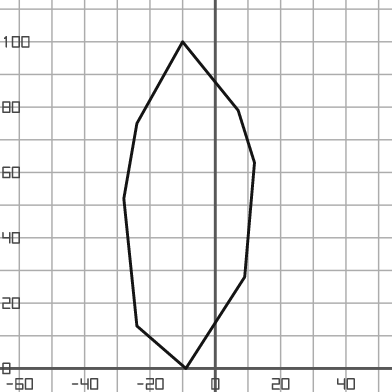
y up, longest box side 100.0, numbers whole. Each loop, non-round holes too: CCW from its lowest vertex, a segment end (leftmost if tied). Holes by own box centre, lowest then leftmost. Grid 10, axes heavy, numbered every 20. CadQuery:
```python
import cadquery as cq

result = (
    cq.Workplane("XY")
    .moveTo(-9.0, 0.0)
    .lineTo(9.0, 28.0)
    .lineTo(12.0, 63.0)
    .lineTo(7.0, 79.0)
    .lineTo(-10.0, 100.0)
    .lineTo(-24.0, 75.0)
    .lineTo(-28.0, 52.0)
    .lineTo(-24.0, 13.0)
    .close()
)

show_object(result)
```